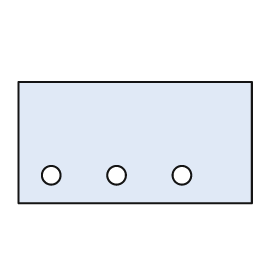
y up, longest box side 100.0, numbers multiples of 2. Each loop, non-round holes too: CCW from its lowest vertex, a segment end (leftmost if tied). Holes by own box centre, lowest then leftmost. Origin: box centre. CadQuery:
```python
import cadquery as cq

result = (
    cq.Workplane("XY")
    .moveTo(-50.0, -26.0)
    .lineTo(50.0, -26.0)
    .lineTo(50.0, 26.0)
    .lineTo(-50.0, 26.0)
    .close()
    .moveTo(-36.0, -14.0)
    .circle(4.0)
    .moveTo(-8.0, -14.0)
    .circle(4.0)
    .moveTo(20.0, -14.0)
    .circle(4.0)
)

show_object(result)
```